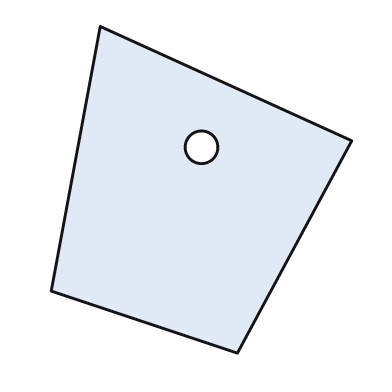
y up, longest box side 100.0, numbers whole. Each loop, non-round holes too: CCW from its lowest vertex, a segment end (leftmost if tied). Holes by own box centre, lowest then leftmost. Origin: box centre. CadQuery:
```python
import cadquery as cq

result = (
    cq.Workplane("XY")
    .moveTo(11.0, -50.0)
    .lineTo(46.0, 15.0)
    .lineTo(-31.0, 50.0)
    .lineTo(-46.0, -31.0)
    .close()
    .moveTo(0.0, 13.0)
    .circle(5.0)
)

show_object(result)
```